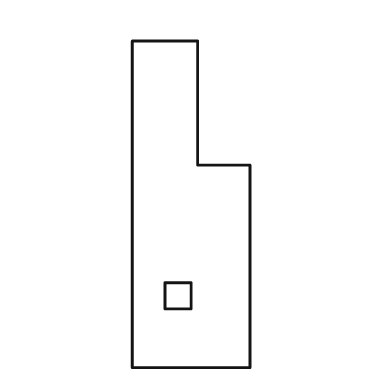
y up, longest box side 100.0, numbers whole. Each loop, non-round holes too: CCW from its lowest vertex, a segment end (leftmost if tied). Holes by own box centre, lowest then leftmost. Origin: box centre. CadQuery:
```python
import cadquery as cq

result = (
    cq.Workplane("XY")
    .moveTo(-18.0, -50.0)
    .lineTo(18.0, -50.0)
    .lineTo(18.0, 12.0)
    .lineTo(2.0, 12.0)
    .lineTo(2.0, 50.0)
    .lineTo(-18.0, 50.0)
    .close()
    .moveTo(-8.0, -32.0)
    .lineTo(0.0, -32.0)
    .lineTo(0.0, -24.0)
    .lineTo(-8.0, -24.0)
    .close()
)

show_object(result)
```